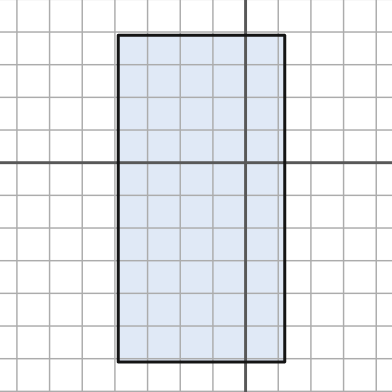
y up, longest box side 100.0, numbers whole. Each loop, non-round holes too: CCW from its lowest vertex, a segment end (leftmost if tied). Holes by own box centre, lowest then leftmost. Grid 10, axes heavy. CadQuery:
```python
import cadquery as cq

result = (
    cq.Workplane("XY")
    .moveTo(-39.0, -61.0)
    .lineTo(12.0, -61.0)
    .lineTo(12.0, 39.0)
    .lineTo(-39.0, 39.0)
    .close()
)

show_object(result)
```